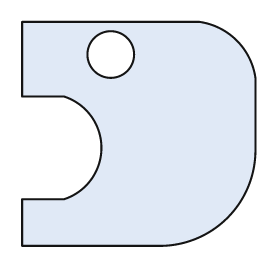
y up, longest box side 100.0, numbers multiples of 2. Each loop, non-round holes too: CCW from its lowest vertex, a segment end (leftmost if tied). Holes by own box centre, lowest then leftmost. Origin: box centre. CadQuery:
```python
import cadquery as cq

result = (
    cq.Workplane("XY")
    .moveTo(-50.0, -48.0)
    .lineTo(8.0, -48.0)
    .threePointArc((38.0, -36.0), (50.0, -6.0))
    .lineTo(50.0, 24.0)
    .threePointArc((42.0, 40.0), (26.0, 48.0))
    .lineTo(-50.0, 48.0)
    .lineTo(-50.0, 16.0)
    .lineTo(-32.0, 16.0)
    .threePointArc((-16.0, -6.0), (-32.0, -28.0))
    .lineTo(-50.0, -28.0)
    .close()
    .moveTo(-12.0, 34.0)
    .circle(10.0)
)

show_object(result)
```